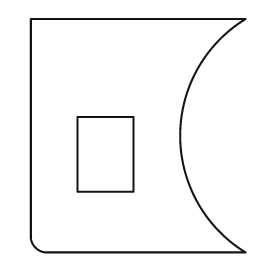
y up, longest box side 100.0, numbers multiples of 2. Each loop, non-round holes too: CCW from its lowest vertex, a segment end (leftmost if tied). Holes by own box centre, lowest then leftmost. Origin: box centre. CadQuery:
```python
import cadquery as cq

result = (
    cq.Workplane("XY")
    .moveTo(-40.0, -50.0)
    .lineTo(46.0, -50.0)
    .threePointArc((18.0, 0.0), (46.0, 50.0))
    .lineTo(-46.0, 50.0)
    .lineTo(-46.0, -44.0)
    .threePointArc((-44.0, -48.0), (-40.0, -50.0))
    .close()
    .moveTo(-26.0, -24.0)
    .lineTo(-2.0, -24.0)
    .lineTo(-2.0, 8.0)
    .lineTo(-26.0, 8.0)
    .close()
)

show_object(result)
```